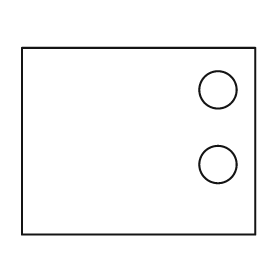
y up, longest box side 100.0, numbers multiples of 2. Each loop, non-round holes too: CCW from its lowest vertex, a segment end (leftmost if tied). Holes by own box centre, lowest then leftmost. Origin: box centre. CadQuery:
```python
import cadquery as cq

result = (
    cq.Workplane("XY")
    .moveTo(-50.0, -40.0)
    .lineTo(50.0, -40.0)
    .lineTo(50.0, 40.0)
    .lineTo(-50.0, 40.0)
    .close()
    .moveTo(34.0, -10.0)
    .circle(8.0)
    .moveTo(34.0, 22.0)
    .circle(8.0)
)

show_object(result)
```